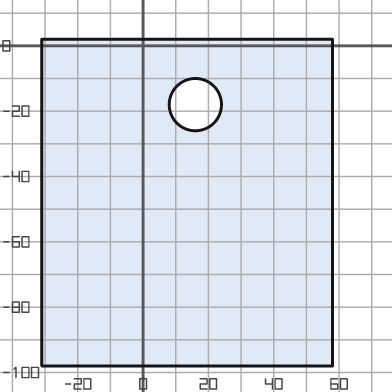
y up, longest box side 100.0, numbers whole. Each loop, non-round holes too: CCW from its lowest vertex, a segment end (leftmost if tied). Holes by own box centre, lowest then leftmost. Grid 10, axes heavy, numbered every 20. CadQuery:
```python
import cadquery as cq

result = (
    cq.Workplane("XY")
    .moveTo(-31.0, -98.0)
    .lineTo(58.0, -98.0)
    .lineTo(58.0, 2.0)
    .lineTo(-31.0, 2.0)
    .close()
    .moveTo(16.0, -18.0)
    .circle(8.0)
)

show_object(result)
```